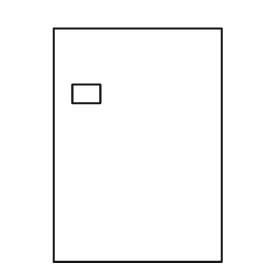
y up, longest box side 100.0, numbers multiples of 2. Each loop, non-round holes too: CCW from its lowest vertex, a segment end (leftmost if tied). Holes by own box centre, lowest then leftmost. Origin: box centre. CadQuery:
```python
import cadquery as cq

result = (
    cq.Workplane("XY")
    .moveTo(-36.0, -50.0)
    .lineTo(36.0, -50.0)
    .lineTo(36.0, 50.0)
    .lineTo(-36.0, 50.0)
    .close()
    .moveTo(-28.0, 18.0)
    .lineTo(-16.0, 18.0)
    .lineTo(-16.0, 26.0)
    .lineTo(-28.0, 26.0)
    .close()
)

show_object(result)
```